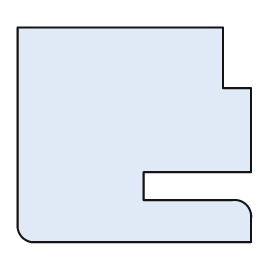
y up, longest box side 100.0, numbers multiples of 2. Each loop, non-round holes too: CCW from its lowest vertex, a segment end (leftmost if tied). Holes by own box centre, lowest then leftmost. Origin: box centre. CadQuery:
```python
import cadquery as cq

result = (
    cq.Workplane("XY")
    .moveTo(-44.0, -46.0)
    .lineTo(50.0, -46.0)
    .lineTo(50.0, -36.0)
    .threePointArc((48.0, -30.0), (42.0, -28.0))
    .lineTo(4.0, -28.0)
    .lineTo(4.0, -16.0)
    .lineTo(50.0, -16.0)
    .lineTo(50.0, 20.0)
    .lineTo(38.0, 20.0)
    .lineTo(38.0, 46.0)
    .lineTo(-50.0, 46.0)
    .lineTo(-50.0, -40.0)
    .threePointArc((-48.0, -44.0), (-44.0, -46.0))
    .close()
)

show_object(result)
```